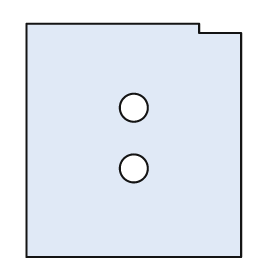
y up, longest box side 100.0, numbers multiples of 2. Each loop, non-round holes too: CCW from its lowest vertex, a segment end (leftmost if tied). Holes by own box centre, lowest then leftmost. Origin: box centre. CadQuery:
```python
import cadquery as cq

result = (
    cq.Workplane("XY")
    .moveTo(-46.0, -50.0)
    .lineTo(46.0, -50.0)
    .lineTo(46.0, 46.0)
    .lineTo(28.0, 46.0)
    .lineTo(28.0, 50.0)
    .lineTo(-46.0, 50.0)
    .close()
    .moveTo(0.0, -12.0)
    .circle(6.0)
    .moveTo(0.0, 14.0)
    .circle(6.0)
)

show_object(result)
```